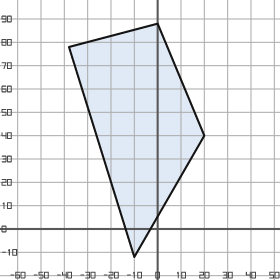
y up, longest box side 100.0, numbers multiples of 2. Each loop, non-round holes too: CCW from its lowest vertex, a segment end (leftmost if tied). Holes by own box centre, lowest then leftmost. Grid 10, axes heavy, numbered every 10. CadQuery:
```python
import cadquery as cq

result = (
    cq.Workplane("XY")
    .moveTo(-10.0, -12.0)
    .lineTo(20.0, 40.0)
    .lineTo(0.0, 88.0)
    .lineTo(-38.0, 78.0)
    .close()
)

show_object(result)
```